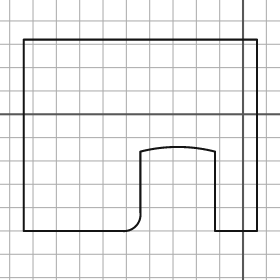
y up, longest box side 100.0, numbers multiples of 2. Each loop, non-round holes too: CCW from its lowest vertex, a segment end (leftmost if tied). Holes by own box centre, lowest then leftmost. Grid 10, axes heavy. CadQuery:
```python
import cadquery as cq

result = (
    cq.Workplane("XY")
    .moveTo(-94.0, -50.0)
    .lineTo(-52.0, -50.0)
    .threePointArc((-46.0, -48.0), (-44.0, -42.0))
    .lineTo(-44.0, -16.0)
    .threePointArc((-28.0, -14.0), (-12.0, -16.0))
    .lineTo(-12.0, -50.0)
    .lineTo(6.0, -50.0)
    .lineTo(6.0, 32.0)
    .lineTo(-94.0, 32.0)
    .close()
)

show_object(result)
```